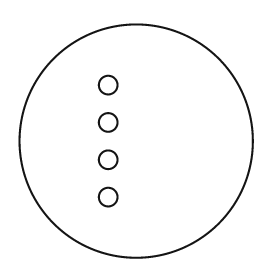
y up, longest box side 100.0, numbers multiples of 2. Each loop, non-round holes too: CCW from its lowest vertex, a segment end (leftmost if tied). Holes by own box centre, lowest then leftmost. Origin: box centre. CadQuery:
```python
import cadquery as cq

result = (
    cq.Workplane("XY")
    .moveTo(0.0, 0.0)
    .circle(50.0)
    .moveTo(-12.0, -24.0)
    .circle(4.0)
    .moveTo(-12.0, -8.0)
    .circle(4.0)
    .moveTo(-12.0, 8.0)
    .circle(4.0)
    .moveTo(-12.0, 24.0)
    .circle(4.0)
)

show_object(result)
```